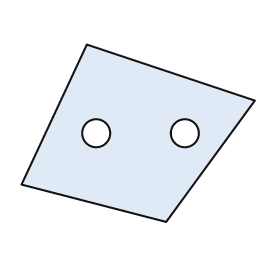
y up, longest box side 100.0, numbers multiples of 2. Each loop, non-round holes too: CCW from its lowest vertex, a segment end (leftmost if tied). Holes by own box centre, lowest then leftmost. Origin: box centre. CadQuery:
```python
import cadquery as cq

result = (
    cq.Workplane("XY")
    .moveTo(12.0, -38.0)
    .lineTo(50.0, 14.0)
    .lineTo(-22.0, 38.0)
    .lineTo(-50.0, -22.0)
    .close()
    .moveTo(-18.0, 0.0)
    .circle(6.0)
    .moveTo(20.0, 0.0)
    .circle(6.0)
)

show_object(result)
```